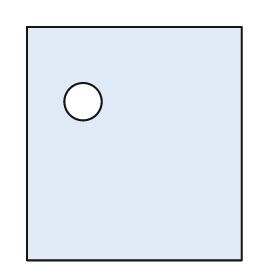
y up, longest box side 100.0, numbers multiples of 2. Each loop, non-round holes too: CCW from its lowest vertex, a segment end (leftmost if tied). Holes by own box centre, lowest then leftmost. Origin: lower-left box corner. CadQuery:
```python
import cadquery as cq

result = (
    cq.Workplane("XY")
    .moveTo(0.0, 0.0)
    .lineTo(92.0, 0.0)
    .lineTo(92.0, 100.0)
    .lineTo(0.0, 100.0)
    .close()
    .moveTo(24.0, 68.0)
    .circle(8.0)
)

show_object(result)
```